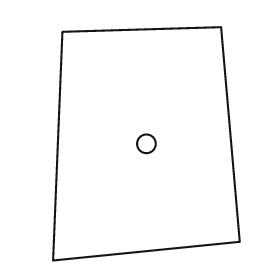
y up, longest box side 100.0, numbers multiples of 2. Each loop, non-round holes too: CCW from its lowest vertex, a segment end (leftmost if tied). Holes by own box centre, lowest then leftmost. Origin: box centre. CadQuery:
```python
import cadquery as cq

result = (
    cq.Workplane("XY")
    .moveTo(-40.0, -50.0)
    .lineTo(40.0, -42.0)
    .lineTo(32.0, 50.0)
    .lineTo(-36.0, 48.0)
    .close()
    .moveTo(0.0, 0.0)
    .circle(4.0)
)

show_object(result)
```